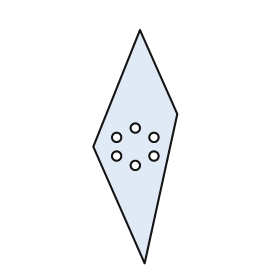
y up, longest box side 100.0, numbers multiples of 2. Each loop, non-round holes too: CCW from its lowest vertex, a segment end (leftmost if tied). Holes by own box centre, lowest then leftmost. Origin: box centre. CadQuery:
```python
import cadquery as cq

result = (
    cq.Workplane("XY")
    .moveTo(4.0, -50.0)
    .lineTo(18.0, 14.0)
    .lineTo(2.0, 50.0)
    .lineTo(-18.0, 0.0)
    .close()
    .moveTo(0.0, -8.0)
    .circle(2.0)
    .moveTo(-8.0, -4.0)
    .circle(2.0)
    .moveTo(8.0, -4.0)
    .circle(2.0)
    .moveTo(-8.0, 4.0)
    .circle(2.0)
    .moveTo(8.0, 4.0)
    .circle(2.0)
    .moveTo(0.0, 8.0)
    .circle(2.0)
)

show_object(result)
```